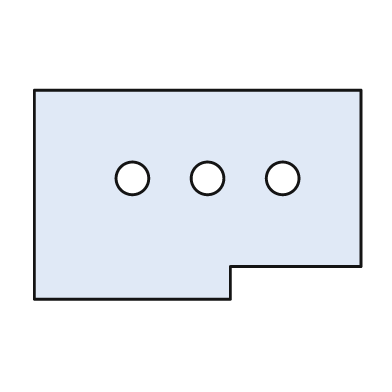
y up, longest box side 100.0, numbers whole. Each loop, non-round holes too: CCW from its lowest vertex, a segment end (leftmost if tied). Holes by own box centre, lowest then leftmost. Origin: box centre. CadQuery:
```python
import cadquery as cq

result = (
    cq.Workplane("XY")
    .moveTo(-50.0, -32.0)
    .lineTo(10.0, -32.0)
    .lineTo(10.0, -22.0)
    .lineTo(50.0, -22.0)
    .lineTo(50.0, 32.0)
    .lineTo(-50.0, 32.0)
    .close()
    .moveTo(-20.0, 5.0)
    .circle(5.0)
    .moveTo(3.0, 5.0)
    .circle(5.0)
    .moveTo(26.0, 5.0)
    .circle(5.0)
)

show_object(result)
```